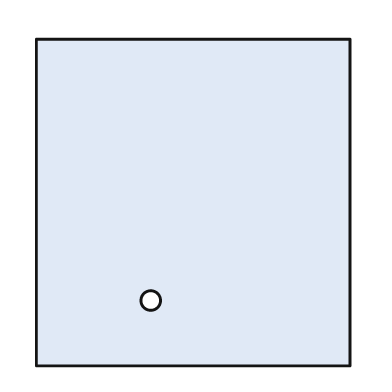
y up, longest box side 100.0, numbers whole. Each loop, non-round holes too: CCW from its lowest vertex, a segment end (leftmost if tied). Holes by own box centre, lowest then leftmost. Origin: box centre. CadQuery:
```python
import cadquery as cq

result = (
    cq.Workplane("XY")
    .moveTo(-48.0, -50.0)
    .lineTo(48.0, -50.0)
    .lineTo(48.0, 50.0)
    .lineTo(-48.0, 50.0)
    .close()
    .moveTo(-13.0, -30.0)
    .circle(3.0)
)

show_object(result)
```